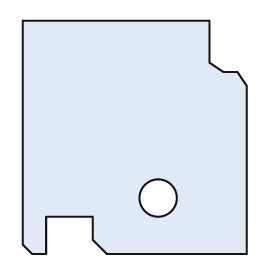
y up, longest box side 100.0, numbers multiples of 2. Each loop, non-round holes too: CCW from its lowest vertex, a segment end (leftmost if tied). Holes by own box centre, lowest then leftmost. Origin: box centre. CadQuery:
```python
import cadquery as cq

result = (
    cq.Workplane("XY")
    .moveTo(-44.0, -50.0)
    .lineTo(-38.0, -50.0)
    .lineTo(-38.0, -34.0)
    .lineTo(-18.0, -34.0)
    .lineTo(-18.0, -44.0)
    .lineTo(-12.0, -50.0)
    .lineTo(48.0, -50.0)
    .lineTo(48.0, 22.0)
    .lineTo(44.0, 28.0)
    .lineTo(38.0, 28.0)
    .lineTo(32.0, 32.0)
    .lineTo(32.0, 50.0)
    .lineTo(-48.0, 50.0)
    .lineTo(-48.0, -46.0)
    .close()
    .moveTo(10.0, -26.0)
    .circle(8.0)
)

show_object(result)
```